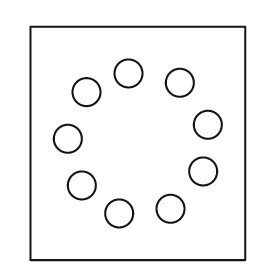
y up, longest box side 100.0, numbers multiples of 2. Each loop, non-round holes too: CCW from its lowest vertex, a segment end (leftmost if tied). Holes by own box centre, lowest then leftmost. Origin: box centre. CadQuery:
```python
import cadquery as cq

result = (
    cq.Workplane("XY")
    .moveTo(-46.0, -50.0)
    .lineTo(46.0, -50.0)
    .lineTo(46.0, 50.0)
    .lineTo(-46.0, 50.0)
    .close()
    .moveTo(-8.0, -30.0)
    .circle(6.0)
    .moveTo(14.0, -28.0)
    .circle(6.0)
    .moveTo(-24.0, -18.0)
    .circle(6.0)
    .moveTo(28.0, -12.0)
    .circle(6.0)
    .moveTo(-30.0, 2.0)
    .circle(6.0)
    .moveTo(30.0, 8.0)
    .circle(6.0)
    .moveTo(-22.0, 22.0)
    .circle(6.0)
    .moveTo(18.0, 26.0)
    .circle(6.0)
    .moveTo(-4.0, 30.0)
    .circle(6.0)
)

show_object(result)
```